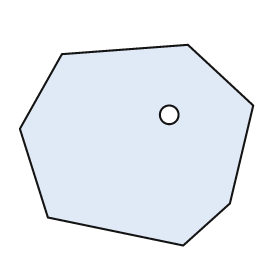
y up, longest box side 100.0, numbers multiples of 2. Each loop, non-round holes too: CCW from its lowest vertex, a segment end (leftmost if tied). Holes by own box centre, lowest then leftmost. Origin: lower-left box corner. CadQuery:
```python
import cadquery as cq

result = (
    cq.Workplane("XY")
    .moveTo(70.0, 0.0)
    .lineTo(90.0, 18.0)
    .lineTo(100.0, 60.0)
    .lineTo(72.0, 86.0)
    .lineTo(18.0, 82.0)
    .lineTo(0.0, 50.0)
    .lineTo(12.0, 12.0)
    .close()
    .moveTo(64.0, 56.0)
    .circle(4.0)
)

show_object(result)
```